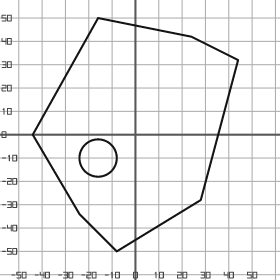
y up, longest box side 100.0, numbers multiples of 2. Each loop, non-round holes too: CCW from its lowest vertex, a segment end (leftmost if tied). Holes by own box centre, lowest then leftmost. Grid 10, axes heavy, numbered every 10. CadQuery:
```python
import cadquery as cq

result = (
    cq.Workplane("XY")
    .moveTo(-8.0, -50.0)
    .lineTo(28.0, -28.0)
    .lineTo(44.0, 32.0)
    .lineTo(24.0, 42.0)
    .lineTo(-16.0, 50.0)
    .lineTo(-44.0, 0.0)
    .lineTo(-24.0, -34.0)
    .close()
    .moveTo(-16.0, -10.0)
    .circle(8.0)
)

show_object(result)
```